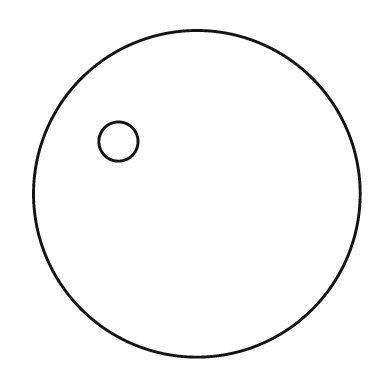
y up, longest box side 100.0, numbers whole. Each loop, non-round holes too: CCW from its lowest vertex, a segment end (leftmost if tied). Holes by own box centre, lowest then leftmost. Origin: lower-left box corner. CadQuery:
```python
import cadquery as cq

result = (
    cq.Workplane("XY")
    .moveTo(50.0, 50.0)
    .circle(50.0)
    .moveTo(26.0, 66.0)
    .circle(6.0)
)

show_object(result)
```